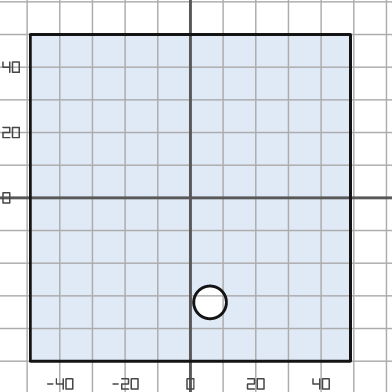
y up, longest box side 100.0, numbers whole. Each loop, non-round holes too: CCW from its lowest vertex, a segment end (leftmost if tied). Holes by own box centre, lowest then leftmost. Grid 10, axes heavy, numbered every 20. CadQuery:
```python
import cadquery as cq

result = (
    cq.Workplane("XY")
    .moveTo(-49.0, -50.0)
    .lineTo(49.0, -50.0)
    .lineTo(49.0, 50.0)
    .lineTo(-49.0, 50.0)
    .close()
    .moveTo(6.0, -32.0)
    .circle(5.0)
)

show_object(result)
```